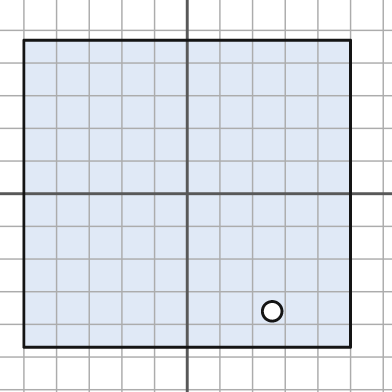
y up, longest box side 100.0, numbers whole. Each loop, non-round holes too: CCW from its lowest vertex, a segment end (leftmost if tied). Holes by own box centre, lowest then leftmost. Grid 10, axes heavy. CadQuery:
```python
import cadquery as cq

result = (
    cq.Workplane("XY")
    .moveTo(-50.0, -47.0)
    .lineTo(50.0, -47.0)
    .lineTo(50.0, 47.0)
    .lineTo(-50.0, 47.0)
    .close()
    .moveTo(26.0, -36.0)
    .circle(3.0)
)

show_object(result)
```